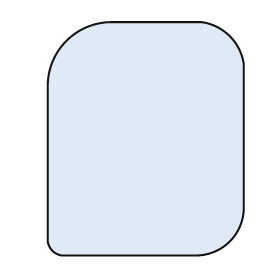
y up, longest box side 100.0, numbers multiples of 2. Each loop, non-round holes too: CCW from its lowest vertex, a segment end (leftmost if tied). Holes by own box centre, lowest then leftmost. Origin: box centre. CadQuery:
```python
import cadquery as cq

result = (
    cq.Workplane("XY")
    .moveTo(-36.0, -50.0)
    .lineTo(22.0, -50.0)
    .threePointArc((36.0, -44.0), (42.0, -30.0))
    .lineTo(42.0, 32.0)
    .threePointArc((36.0, 44.0), (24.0, 50.0))
    .lineTo(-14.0, 50.0)
    .threePointArc((-34.0, 42.0), (-42.0, 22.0))
    .lineTo(-42.0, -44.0)
    .threePointArc((-40.0, -48.0), (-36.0, -50.0))
    .close()
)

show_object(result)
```